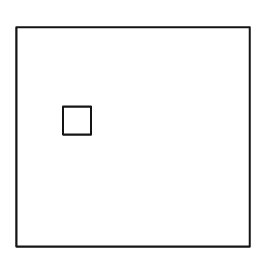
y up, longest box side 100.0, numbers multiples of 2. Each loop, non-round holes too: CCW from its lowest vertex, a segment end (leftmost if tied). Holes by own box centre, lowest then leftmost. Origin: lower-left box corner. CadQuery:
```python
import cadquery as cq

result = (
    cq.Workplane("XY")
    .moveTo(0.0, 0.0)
    .lineTo(100.0, 0.0)
    .lineTo(100.0, 94.0)
    .lineTo(0.0, 94.0)
    .close()
    .moveTo(20.0, 48.0)
    .lineTo(32.0, 48.0)
    .lineTo(32.0, 60.0)
    .lineTo(20.0, 60.0)
    .close()
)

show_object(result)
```